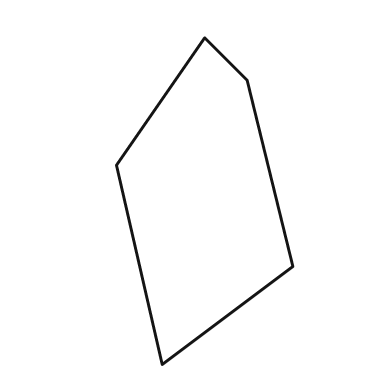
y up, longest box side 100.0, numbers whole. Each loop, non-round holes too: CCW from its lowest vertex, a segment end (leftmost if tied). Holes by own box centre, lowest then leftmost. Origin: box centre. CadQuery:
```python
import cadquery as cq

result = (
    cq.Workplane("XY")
    .moveTo(-13.0, -50.0)
    .lineTo(27.0, -20.0)
    .lineTo(13.0, 37.0)
    .lineTo(0.0, 50.0)
    .lineTo(-27.0, 11.0)
    .close()
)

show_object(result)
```